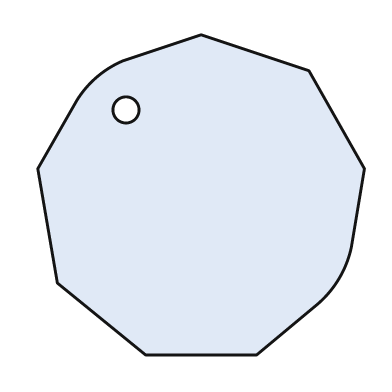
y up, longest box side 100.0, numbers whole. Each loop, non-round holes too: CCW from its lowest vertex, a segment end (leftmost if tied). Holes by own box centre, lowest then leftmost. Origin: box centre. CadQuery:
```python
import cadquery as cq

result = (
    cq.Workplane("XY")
    .moveTo(-17.0, -49.0)
    .lineTo(17.0, -49.0)
    .lineTo(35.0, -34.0)
    .threePointArc((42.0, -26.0), (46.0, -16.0))
    .lineTo(50.0, 8.0)
    .lineTo(33.0, 38.0)
    .lineTo(0.0, 49.0)
    .lineTo(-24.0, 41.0)
    .threePointArc((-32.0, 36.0), (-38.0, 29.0))
    .lineTo(-50.0, 8.0)
    .lineTo(-44.0, -27.0)
    .close()
    .moveTo(-23.0, 26.0)
    .circle(4.0)
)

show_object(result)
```